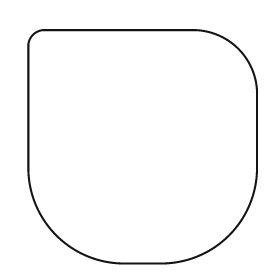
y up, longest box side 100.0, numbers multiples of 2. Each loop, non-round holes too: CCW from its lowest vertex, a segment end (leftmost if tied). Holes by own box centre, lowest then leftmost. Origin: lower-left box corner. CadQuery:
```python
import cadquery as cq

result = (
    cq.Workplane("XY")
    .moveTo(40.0, 0.0)
    .lineTo(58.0, 0.0)
    .threePointArc((86.0, 12.0), (98.0, 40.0))
    .lineTo(98.0, 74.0)
    .threePointArc((90.0, 92.0), (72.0, 100.0))
    .lineTo(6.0, 100.0)
    .threePointArc((2.0, 98.0), (0.0, 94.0))
    .lineTo(0.0, 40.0)
    .threePointArc((12.0, 12.0), (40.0, 0.0))
    .close()
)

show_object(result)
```